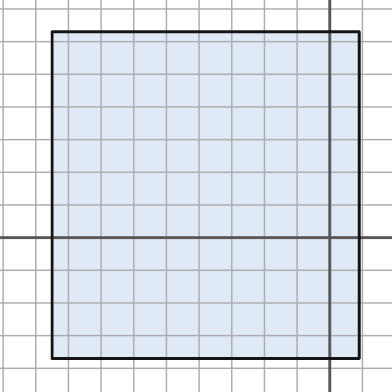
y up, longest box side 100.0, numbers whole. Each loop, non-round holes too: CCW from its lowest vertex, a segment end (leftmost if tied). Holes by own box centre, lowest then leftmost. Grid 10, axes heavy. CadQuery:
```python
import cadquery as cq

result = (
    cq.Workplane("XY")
    .moveTo(-85.0, -37.0)
    .lineTo(9.0, -37.0)
    .lineTo(9.0, 63.0)
    .lineTo(-85.0, 63.0)
    .close()
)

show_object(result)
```